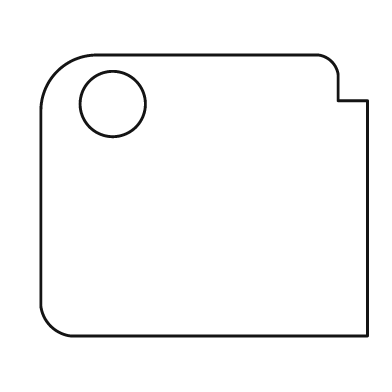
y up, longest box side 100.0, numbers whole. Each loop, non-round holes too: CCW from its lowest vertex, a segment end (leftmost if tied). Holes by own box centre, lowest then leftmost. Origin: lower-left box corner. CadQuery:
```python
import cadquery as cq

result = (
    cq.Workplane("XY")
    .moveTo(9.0, 0.0)
    .lineTo(100.0, 0.0)
    .lineTo(100.0, 72.0)
    .lineTo(91.0, 72.0)
    .lineTo(91.0, 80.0)
    .threePointArc((89.0, 84.0), (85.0, 86.0))
    .lineTo(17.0, 86.0)
    .threePointArc((5.0, 81.0), (0.0, 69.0))
    .lineTo(0.0, 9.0)
    .threePointArc((3.0, 3.0), (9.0, 0.0))
    .close()
    .moveTo(22.0, 71.0)
    .circle(10.0)
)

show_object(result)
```